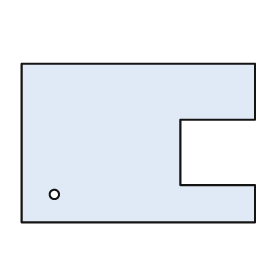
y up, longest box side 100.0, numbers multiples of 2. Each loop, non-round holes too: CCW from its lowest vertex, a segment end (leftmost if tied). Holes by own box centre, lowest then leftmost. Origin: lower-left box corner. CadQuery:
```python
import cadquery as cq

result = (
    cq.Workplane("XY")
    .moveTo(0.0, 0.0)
    .lineTo(100.0, 0.0)
    .lineTo(100.0, 16.0)
    .lineTo(68.0, 16.0)
    .lineTo(68.0, 44.0)
    .lineTo(100.0, 44.0)
    .lineTo(100.0, 68.0)
    .lineTo(0.0, 68.0)
    .close()
    .moveTo(14.0, 12.0)
    .circle(2.0)
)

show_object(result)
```